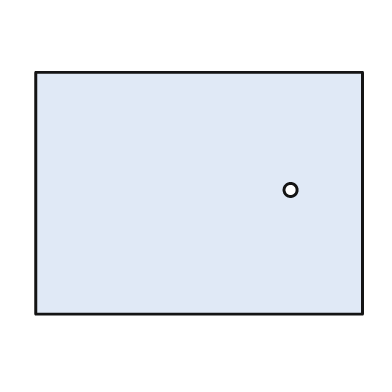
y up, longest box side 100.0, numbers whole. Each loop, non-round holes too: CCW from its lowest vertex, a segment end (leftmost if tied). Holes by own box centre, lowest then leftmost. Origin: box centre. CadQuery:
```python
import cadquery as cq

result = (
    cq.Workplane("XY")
    .moveTo(-50.0, -37.0)
    .lineTo(50.0, -37.0)
    .lineTo(50.0, 37.0)
    .lineTo(-50.0, 37.0)
    .close()
    .moveTo(28.0, 1.0)
    .circle(2.0)
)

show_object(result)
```